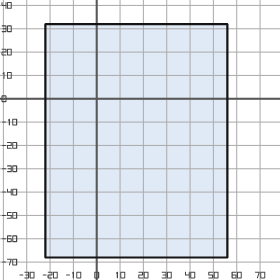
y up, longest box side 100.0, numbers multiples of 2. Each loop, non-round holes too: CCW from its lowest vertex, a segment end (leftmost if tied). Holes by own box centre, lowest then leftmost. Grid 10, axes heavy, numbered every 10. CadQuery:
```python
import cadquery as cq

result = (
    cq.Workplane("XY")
    .moveTo(-22.0, -68.0)
    .lineTo(56.0, -68.0)
    .lineTo(56.0, 32.0)
    .lineTo(-22.0, 32.0)
    .close()
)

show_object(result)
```